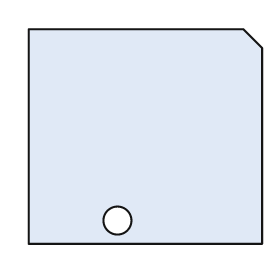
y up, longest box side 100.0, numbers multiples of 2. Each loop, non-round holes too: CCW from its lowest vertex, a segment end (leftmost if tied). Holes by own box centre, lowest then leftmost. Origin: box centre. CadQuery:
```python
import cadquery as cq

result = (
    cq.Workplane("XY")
    .moveTo(-50.0, -46.0)
    .lineTo(50.0, -46.0)
    .lineTo(50.0, 38.0)
    .lineTo(42.0, 46.0)
    .lineTo(-50.0, 46.0)
    .close()
    .moveTo(-12.0, -36.0)
    .circle(6.0)
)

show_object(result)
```